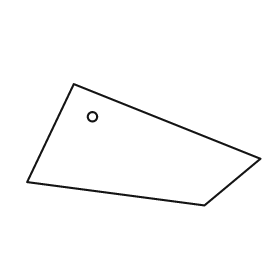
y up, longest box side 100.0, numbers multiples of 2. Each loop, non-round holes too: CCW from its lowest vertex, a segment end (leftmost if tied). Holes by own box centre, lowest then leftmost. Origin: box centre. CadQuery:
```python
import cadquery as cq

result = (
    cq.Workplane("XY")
    .moveTo(26.0, -26.0)
    .lineTo(50.0, -6.0)
    .lineTo(-30.0, 26.0)
    .lineTo(-50.0, -16.0)
    .close()
    .moveTo(-22.0, 12.0)
    .circle(2.0)
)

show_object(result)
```